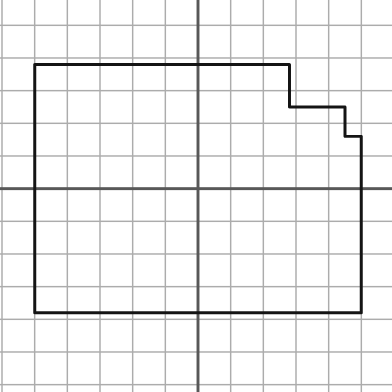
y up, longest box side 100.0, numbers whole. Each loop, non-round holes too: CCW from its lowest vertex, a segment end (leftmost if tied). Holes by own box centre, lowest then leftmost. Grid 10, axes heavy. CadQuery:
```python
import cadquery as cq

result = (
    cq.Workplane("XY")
    .moveTo(-50.0, -38.0)
    .lineTo(50.0, -38.0)
    .lineTo(50.0, 16.0)
    .lineTo(45.0, 16.0)
    .lineTo(45.0, 25.0)
    .lineTo(28.0, 25.0)
    .lineTo(28.0, 38.0)
    .lineTo(-50.0, 38.0)
    .close()
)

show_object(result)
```